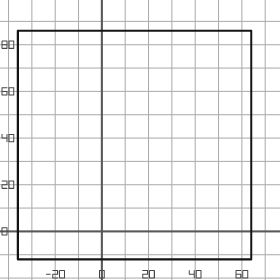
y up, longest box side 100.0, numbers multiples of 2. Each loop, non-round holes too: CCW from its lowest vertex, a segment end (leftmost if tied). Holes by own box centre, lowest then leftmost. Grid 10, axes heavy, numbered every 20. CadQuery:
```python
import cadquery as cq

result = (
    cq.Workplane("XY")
    .moveTo(-36.0, -12.0)
    .lineTo(64.0, -12.0)
    .lineTo(64.0, 86.0)
    .lineTo(-36.0, 86.0)
    .close()
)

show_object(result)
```